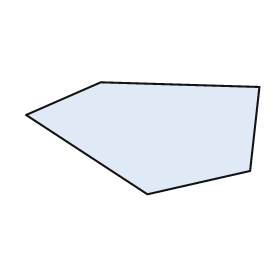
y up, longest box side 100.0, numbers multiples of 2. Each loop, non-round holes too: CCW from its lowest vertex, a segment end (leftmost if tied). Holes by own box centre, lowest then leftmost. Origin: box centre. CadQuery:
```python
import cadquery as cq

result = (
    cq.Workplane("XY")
    .moveTo(2.0, -24.0)
    .lineTo(46.0, -14.0)
    .lineTo(50.0, 22.0)
    .lineTo(-18.0, 24.0)
    .lineTo(-50.0, 10.0)
    .close()
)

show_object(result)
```